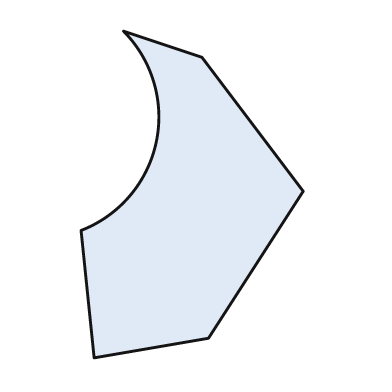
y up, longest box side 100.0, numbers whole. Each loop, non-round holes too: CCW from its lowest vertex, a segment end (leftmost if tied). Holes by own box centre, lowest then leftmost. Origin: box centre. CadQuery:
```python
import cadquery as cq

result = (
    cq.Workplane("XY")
    .moveTo(-30.0, -50.0)
    .lineTo(5.0, -44.0)
    .lineTo(34.0, 1.0)
    .lineTo(3.0, 42.0)
    .lineTo(-21.0, 50.0)
    .threePointArc((-11.0, 16.0), (-34.0, -11.0))
    .close()
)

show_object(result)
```